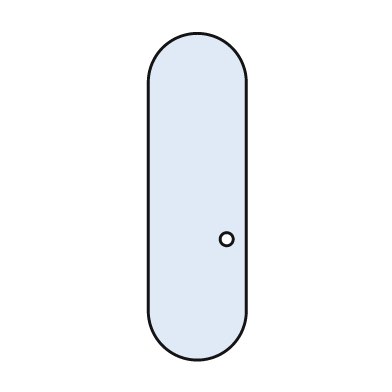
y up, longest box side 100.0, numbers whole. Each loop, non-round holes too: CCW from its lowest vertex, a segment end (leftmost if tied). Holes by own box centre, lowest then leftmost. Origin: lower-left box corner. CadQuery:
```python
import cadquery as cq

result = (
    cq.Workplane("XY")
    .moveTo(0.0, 15.0)
    .threePointArc((15.0, 0.0), (30.0, 15.0))
    .lineTo(30.0, 85.0)
    .threePointArc((15.0, 100.0), (0.0, 85.0))
    .close()
    .moveTo(24.0, 37.0)
    .circle(2.0)
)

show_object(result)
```